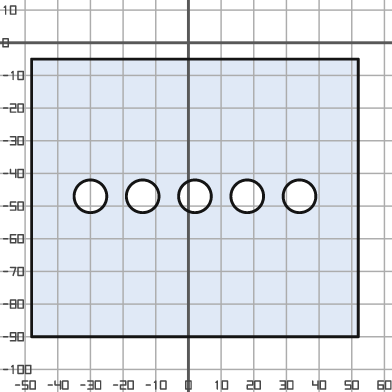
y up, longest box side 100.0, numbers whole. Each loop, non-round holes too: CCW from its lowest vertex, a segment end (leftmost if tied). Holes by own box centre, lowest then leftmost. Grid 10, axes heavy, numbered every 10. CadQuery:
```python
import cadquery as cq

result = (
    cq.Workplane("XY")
    .moveTo(-48.0, -90.0)
    .lineTo(52.0, -90.0)
    .lineTo(52.0, -5.0)
    .lineTo(-48.0, -5.0)
    .close()
    .moveTo(-30.0, -47.0)
    .circle(5.0)
    .moveTo(-14.0, -47.0)
    .circle(5.0)
    .moveTo(2.0, -47.0)
    .circle(5.0)
    .moveTo(18.0, -47.0)
    .circle(5.0)
    .moveTo(34.0, -47.0)
    .circle(5.0)
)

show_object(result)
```